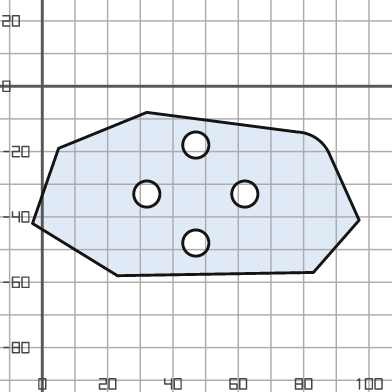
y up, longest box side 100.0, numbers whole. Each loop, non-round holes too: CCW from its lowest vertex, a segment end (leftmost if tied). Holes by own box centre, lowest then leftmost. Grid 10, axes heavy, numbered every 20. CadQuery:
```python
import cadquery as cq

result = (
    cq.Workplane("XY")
    .moveTo(23.0, -58.0)
    .lineTo(83.0, -57.0)
    .lineTo(97.0, -41.0)
    .lineTo(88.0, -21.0)
    .threePointArc((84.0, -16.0), (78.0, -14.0))
    .lineTo(32.0, -8.0)
    .lineTo(5.0, -19.0)
    .lineTo(-3.0, -42.0)
    .close()
    .moveTo(47.0, -48.0)
    .circle(4.0)
    .moveTo(32.0, -33.0)
    .circle(4.0)
    .moveTo(62.0, -33.0)
    .circle(4.0)
    .moveTo(47.0, -18.0)
    .circle(4.0)
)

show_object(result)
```